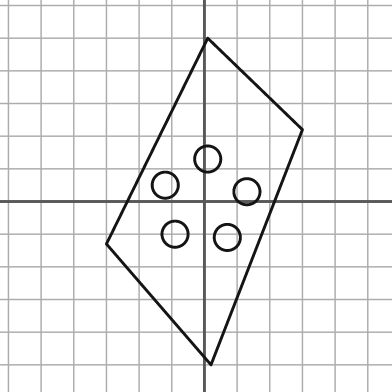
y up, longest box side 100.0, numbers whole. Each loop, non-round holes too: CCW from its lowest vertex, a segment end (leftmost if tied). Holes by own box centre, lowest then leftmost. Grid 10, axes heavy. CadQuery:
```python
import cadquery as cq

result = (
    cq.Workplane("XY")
    .moveTo(2.0, -50.0)
    .lineTo(30.0, 22.0)
    .lineTo(1.0, 50.0)
    .lineTo(-30.0, -13.0)
    .close()
    .moveTo(7.0, -11.0)
    .circle(4.0)
    .moveTo(-9.0, -10.0)
    .circle(4.0)
    .moveTo(13.0, 3.0)
    .circle(4.0)
    .moveTo(-12.0, 5.0)
    .circle(4.0)
    .moveTo(1.0, 13.0)
    .circle(4.0)
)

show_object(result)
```